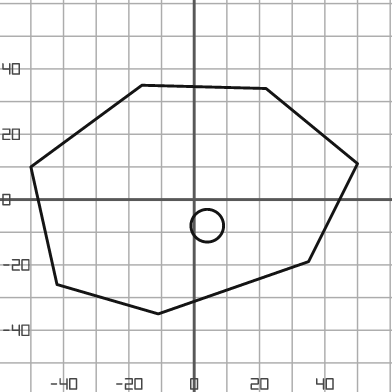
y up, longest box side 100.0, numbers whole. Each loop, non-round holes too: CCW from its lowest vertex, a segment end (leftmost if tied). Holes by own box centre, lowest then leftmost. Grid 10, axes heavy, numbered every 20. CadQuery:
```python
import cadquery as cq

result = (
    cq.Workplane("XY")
    .moveTo(-11.0, -35.0)
    .lineTo(35.0, -19.0)
    .lineTo(50.0, 11.0)
    .lineTo(22.0, 34.0)
    .lineTo(-16.0, 35.0)
    .lineTo(-50.0, 10.0)
    .lineTo(-42.0, -26.0)
    .close()
    .moveTo(4.0, -8.0)
    .circle(5.0)
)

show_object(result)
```